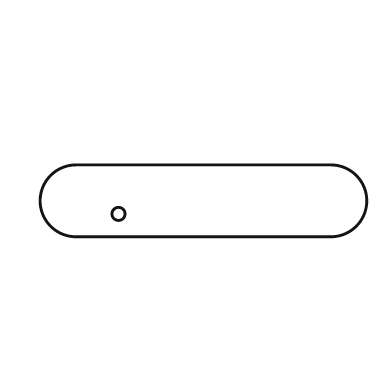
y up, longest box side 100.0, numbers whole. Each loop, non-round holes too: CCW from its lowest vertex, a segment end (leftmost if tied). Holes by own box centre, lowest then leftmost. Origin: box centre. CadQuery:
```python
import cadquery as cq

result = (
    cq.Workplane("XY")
    .moveTo(-39.0, -11.0)
    .lineTo(39.0, -11.0)
    .threePointArc((50.0, 0.0), (39.0, 11.0))
    .lineTo(-39.0, 11.0)
    .threePointArc((-50.0, 0.0), (-39.0, -11.0))
    .close()
    .moveTo(-26.0, -4.0)
    .circle(2.0)
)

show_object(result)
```